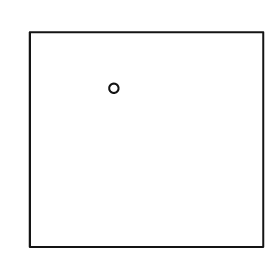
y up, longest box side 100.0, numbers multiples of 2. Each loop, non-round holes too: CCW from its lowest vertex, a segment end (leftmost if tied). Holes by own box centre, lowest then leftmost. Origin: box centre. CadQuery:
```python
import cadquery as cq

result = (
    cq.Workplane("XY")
    .moveTo(-50.0, -46.0)
    .lineTo(50.0, -46.0)
    .lineTo(50.0, 46.0)
    .lineTo(-50.0, 46.0)
    .close()
    .moveTo(-14.0, 22.0)
    .circle(2.0)
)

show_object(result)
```